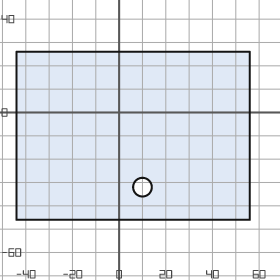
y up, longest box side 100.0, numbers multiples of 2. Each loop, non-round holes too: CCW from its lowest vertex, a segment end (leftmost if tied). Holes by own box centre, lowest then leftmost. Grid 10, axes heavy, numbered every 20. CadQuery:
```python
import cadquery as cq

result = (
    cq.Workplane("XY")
    .moveTo(-44.0, -46.0)
    .lineTo(56.0, -46.0)
    .lineTo(56.0, 26.0)
    .lineTo(-44.0, 26.0)
    .close()
    .moveTo(10.0, -32.0)
    .circle(4.0)
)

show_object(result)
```